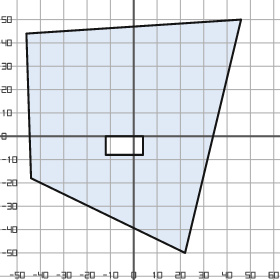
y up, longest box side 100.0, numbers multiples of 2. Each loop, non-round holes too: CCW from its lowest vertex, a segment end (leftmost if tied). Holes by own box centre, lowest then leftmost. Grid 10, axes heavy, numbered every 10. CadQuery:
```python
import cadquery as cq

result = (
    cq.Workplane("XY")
    .moveTo(22.0, -50.0)
    .lineTo(46.0, 50.0)
    .lineTo(-46.0, 44.0)
    .lineTo(-44.0, -18.0)
    .close()
    .moveTo(-12.0, -8.0)
    .lineTo(4.0, -8.0)
    .lineTo(4.0, 0.0)
    .lineTo(-12.0, 0.0)
    .close()
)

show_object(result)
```